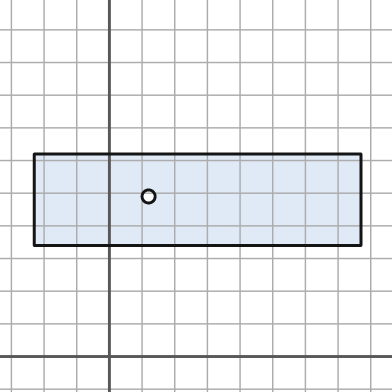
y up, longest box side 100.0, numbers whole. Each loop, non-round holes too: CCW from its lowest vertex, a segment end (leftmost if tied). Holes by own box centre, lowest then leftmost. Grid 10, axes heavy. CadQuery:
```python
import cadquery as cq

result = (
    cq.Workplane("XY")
    .moveTo(-23.0, 34.0)
    .lineTo(77.0, 34.0)
    .lineTo(77.0, 62.0)
    .lineTo(-23.0, 62.0)
    .close()
    .moveTo(12.0, 49.0)
    .circle(2.0)
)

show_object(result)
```